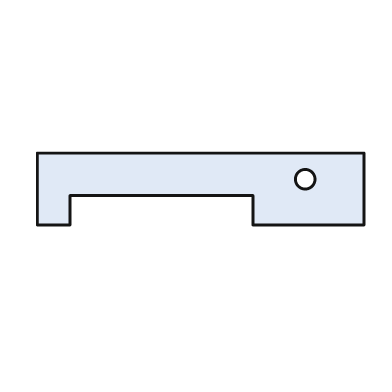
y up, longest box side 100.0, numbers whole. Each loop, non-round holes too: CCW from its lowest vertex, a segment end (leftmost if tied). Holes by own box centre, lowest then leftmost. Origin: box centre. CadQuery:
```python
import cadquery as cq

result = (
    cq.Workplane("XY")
    .moveTo(-50.0, -11.0)
    .lineTo(-40.0, -11.0)
    .lineTo(-40.0, -2.0)
    .lineTo(16.0, -2.0)
    .lineTo(16.0, -11.0)
    .lineTo(50.0, -11.0)
    .lineTo(50.0, 11.0)
    .lineTo(-50.0, 11.0)
    .close()
    .moveTo(32.0, 3.0)
    .circle(3.0)
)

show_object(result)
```